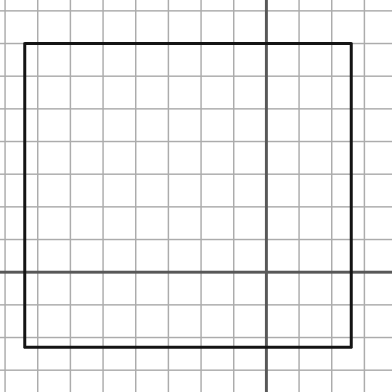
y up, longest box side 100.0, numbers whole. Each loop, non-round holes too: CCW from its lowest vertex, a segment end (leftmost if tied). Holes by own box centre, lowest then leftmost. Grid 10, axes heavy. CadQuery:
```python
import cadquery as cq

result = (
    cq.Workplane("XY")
    .moveTo(-74.0, -23.0)
    .lineTo(26.0, -23.0)
    .lineTo(26.0, 70.0)
    .lineTo(-74.0, 70.0)
    .close()
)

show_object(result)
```